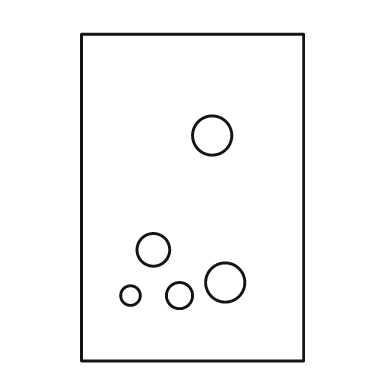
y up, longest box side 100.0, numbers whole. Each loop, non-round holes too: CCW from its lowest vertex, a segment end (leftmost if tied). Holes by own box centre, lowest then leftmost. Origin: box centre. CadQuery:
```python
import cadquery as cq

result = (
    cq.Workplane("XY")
    .moveTo(-34.0, -50.0)
    .lineTo(34.0, -50.0)
    .lineTo(34.0, 50.0)
    .lineTo(-34.0, 50.0)
    .close()
    .moveTo(-19.0, -30.0)
    .circle(3.0)
    .moveTo(-4.0, -30.0)
    .circle(4.0)
    .moveTo(10.0, -26.0)
    .circle(6.0)
    .moveTo(-12.0, -16.0)
    .circle(5.0)
    .moveTo(6.0, 19.0)
    .circle(6.0)
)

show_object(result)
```